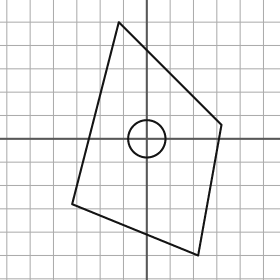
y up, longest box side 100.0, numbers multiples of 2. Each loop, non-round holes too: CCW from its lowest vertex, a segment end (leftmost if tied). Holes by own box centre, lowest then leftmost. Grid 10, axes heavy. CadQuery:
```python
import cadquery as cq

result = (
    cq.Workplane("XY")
    .moveTo(22.0, -50.0)
    .lineTo(32.0, 6.0)
    .lineTo(-12.0, 50.0)
    .lineTo(-32.0, -28.0)
    .close()
    .moveTo(0.0, 0.0)
    .circle(8.0)
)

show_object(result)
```